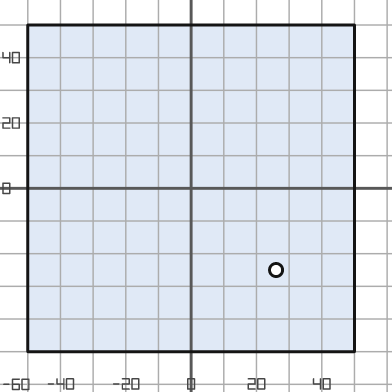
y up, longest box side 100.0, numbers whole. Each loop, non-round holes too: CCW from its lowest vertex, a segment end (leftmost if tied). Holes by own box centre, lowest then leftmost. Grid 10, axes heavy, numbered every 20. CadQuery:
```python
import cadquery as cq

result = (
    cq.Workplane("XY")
    .moveTo(-50.0, -50.0)
    .lineTo(50.0, -50.0)
    .lineTo(50.0, 50.0)
    .lineTo(-50.0, 50.0)
    .close()
    .moveTo(26.0, -25.0)
    .circle(2.0)
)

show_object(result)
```